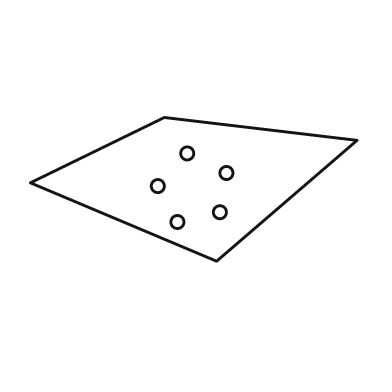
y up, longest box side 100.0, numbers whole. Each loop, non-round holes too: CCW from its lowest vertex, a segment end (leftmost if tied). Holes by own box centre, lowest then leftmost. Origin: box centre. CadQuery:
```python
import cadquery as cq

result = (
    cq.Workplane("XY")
    .moveTo(7.0, -22.0)
    .lineTo(50.0, 15.0)
    .lineTo(-9.0, 22.0)
    .lineTo(-50.0, 2.0)
    .close()
    .moveTo(-5.0, -10.0)
    .circle(2.0)
    .moveTo(8.0, -7.0)
    .circle(2.0)
    .moveTo(-11.0, 1.0)
    .circle(2.0)
    .moveTo(10.0, 5.0)
    .circle(2.0)
    .moveTo(-2.0, 11.0)
    .circle(2.0)
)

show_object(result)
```